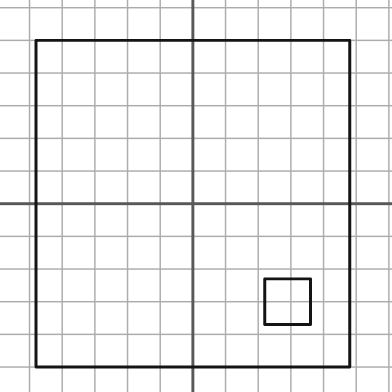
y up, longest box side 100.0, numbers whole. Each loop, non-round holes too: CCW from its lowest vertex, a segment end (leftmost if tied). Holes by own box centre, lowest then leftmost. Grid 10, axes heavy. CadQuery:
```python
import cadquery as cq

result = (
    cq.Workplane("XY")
    .moveTo(-48.0, -50.0)
    .lineTo(48.0, -50.0)
    .lineTo(48.0, 50.0)
    .lineTo(-48.0, 50.0)
    .close()
    .moveTo(22.0, -37.0)
    .lineTo(36.0, -37.0)
    .lineTo(36.0, -23.0)
    .lineTo(22.0, -23.0)
    .close()
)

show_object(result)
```